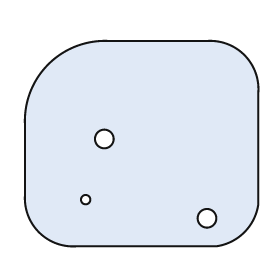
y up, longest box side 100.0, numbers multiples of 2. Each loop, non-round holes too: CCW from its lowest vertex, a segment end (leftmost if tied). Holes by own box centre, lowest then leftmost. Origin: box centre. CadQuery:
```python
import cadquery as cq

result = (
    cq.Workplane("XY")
    .moveTo(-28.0, -44.0)
    .lineTo(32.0, -44.0)
    .threePointArc((44.0, -38.0), (50.0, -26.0))
    .lineTo(50.0, 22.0)
    .threePointArc((44.0, 38.0), (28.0, 44.0))
    .lineTo(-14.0, 44.0)
    .threePointArc((-40.0, 34.0), (-50.0, 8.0))
    .lineTo(-50.0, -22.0)
    .threePointArc((-44.0, -38.0), (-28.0, -44.0))
    .close()
    .moveTo(28.0, -32.0)
    .circle(4.0)
    .moveTo(-24.0, -24.0)
    .circle(2.0)
    .moveTo(-16.0, 2.0)
    .circle(4.0)
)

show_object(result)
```